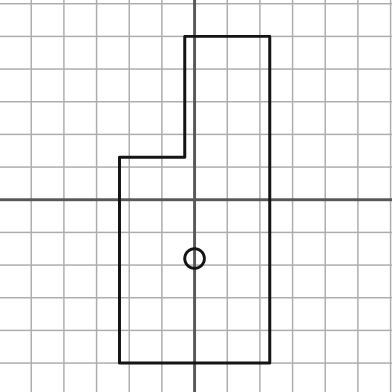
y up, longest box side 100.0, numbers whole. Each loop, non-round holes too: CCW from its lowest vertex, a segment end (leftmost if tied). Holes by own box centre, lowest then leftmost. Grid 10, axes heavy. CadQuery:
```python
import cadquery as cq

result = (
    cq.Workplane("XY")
    .moveTo(-23.0, -50.0)
    .lineTo(23.0, -50.0)
    .lineTo(23.0, 50.0)
    .lineTo(-3.0, 50.0)
    .lineTo(-3.0, 13.0)
    .lineTo(-23.0, 13.0)
    .close()
    .moveTo(0.0, -18.0)
    .circle(3.0)
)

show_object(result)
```